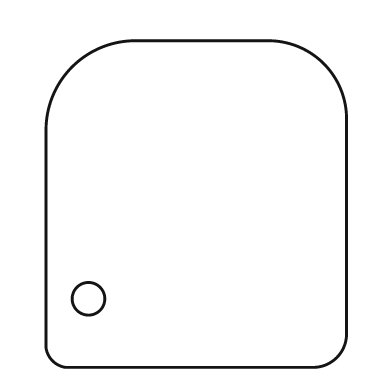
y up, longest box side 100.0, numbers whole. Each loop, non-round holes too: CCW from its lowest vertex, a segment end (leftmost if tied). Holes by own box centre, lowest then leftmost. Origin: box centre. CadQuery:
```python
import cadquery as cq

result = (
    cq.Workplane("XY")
    .moveTo(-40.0, -50.0)
    .lineTo(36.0, -50.0)
    .threePointArc((43.0, -47.0), (46.0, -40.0))
    .lineTo(46.0, 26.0)
    .threePointArc((39.0, 43.0), (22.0, 50.0))
    .lineTo(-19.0, 50.0)
    .threePointArc((-38.0, 42.0), (-46.0, 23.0))
    .lineTo(-46.0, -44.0)
    .threePointArc((-44.0, -48.0), (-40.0, -50.0))
    .close()
    .moveTo(-33.0, -29.0)
    .circle(5.0)
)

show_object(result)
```